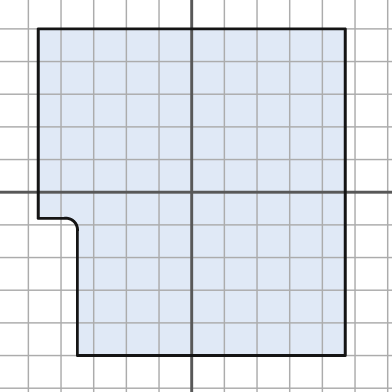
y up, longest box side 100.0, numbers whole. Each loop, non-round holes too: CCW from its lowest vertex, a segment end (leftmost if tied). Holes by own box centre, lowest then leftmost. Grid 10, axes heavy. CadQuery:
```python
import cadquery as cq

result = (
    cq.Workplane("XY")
    .moveTo(-35.0, -50.0)
    .lineTo(47.0, -50.0)
    .lineTo(47.0, 50.0)
    .lineTo(-47.0, 50.0)
    .lineTo(-47.0, -8.0)
    .lineTo(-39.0, -8.0)
    .threePointArc((-36.0, -9.0), (-35.0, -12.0))
    .close()
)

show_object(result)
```